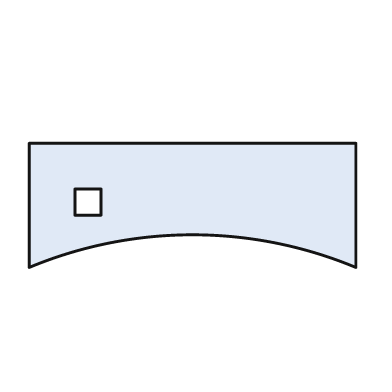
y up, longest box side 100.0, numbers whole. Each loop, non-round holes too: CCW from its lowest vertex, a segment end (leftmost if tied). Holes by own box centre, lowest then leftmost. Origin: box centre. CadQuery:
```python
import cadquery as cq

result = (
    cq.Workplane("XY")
    .moveTo(-50.0, -19.0)
    .threePointArc((0.0, -9.0), (50.0, -19.0))
    .lineTo(50.0, 19.0)
    .lineTo(-50.0, 19.0)
    .close()
    .moveTo(-36.0, -3.0)
    .lineTo(-28.0, -3.0)
    .lineTo(-28.0, 5.0)
    .lineTo(-36.0, 5.0)
    .close()
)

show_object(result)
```